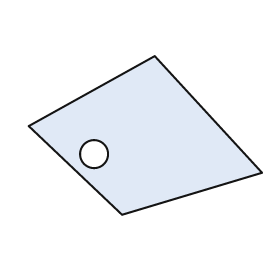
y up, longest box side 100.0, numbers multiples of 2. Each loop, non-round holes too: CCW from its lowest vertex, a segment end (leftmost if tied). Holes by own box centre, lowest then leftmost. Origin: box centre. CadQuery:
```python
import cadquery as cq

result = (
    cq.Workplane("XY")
    .moveTo(-10.0, -34.0)
    .lineTo(50.0, -16.0)
    .lineTo(4.0, 34.0)
    .lineTo(-50.0, 4.0)
    .close()
    .moveTo(-22.0, -8.0)
    .circle(6.0)
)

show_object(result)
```